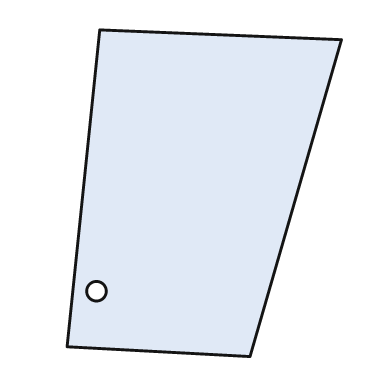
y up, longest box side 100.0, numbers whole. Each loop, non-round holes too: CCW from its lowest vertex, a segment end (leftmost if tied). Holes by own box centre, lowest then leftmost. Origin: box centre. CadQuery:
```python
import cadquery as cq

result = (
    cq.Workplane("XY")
    .moveTo(14.0, -50.0)
    .lineTo(42.0, 47.0)
    .lineTo(-32.0, 50.0)
    .lineTo(-42.0, -47.0)
    .close()
    .moveTo(-33.0, -30.0)
    .circle(3.0)
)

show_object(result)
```